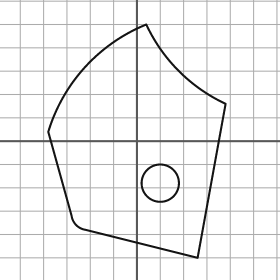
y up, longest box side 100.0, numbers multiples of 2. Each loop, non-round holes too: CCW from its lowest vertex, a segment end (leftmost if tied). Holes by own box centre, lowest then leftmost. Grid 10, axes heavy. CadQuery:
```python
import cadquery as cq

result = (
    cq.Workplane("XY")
    .moveTo(26.0, -50.0)
    .lineTo(38.0, 16.0)
    .threePointArc((18.0, 30.0), (4.0, 50.0))
    .threePointArc((-22.0, 32.0), (-38.0, 4.0))
    .lineTo(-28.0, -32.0)
    .threePointArc((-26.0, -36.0), (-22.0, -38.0))
    .close()
    .moveTo(10.0, -18.0)
    .circle(8.0)
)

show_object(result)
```